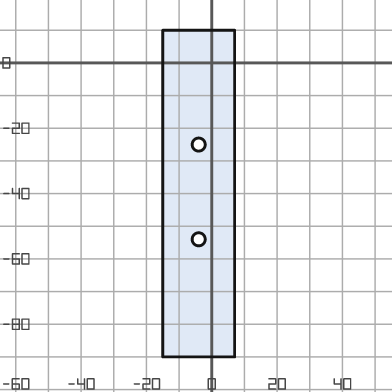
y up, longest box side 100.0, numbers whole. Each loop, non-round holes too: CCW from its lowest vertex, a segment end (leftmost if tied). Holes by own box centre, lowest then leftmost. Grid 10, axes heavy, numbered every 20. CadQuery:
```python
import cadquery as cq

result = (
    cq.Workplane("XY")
    .moveTo(-15.0, -90.0)
    .lineTo(7.0, -90.0)
    .lineTo(7.0, 10.0)
    .lineTo(-15.0, 10.0)
    .close()
    .moveTo(-4.0, -54.0)
    .circle(2.0)
    .moveTo(-4.0, -25.0)
    .circle(2.0)
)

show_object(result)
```